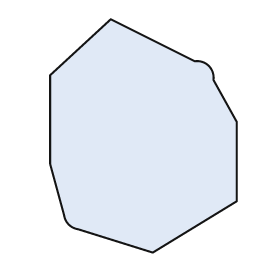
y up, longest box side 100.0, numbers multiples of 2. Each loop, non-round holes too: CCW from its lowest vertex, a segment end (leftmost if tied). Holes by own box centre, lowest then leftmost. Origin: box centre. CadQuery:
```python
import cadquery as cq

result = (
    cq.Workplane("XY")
    .moveTo(4.0, -50.0)
    .lineTo(40.0, -28.0)
    .lineTo(40.0, 6.0)
    .lineTo(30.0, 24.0)
    .threePointArc((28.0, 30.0), (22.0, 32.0))
    .lineTo(-14.0, 50.0)
    .lineTo(-40.0, 26.0)
    .lineTo(-40.0, -12.0)
    .lineTo(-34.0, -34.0)
    .threePointArc((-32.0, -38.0), (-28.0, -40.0))
    .close()
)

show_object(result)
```